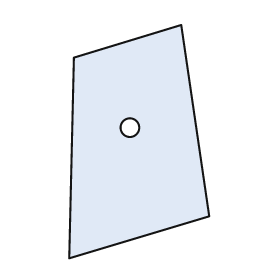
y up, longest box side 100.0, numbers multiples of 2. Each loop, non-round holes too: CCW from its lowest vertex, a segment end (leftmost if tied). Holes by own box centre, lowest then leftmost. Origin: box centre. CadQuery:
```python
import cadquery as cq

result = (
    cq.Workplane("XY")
    .moveTo(-30.0, -50.0)
    .lineTo(30.0, -32.0)
    .lineTo(18.0, 50.0)
    .lineTo(-28.0, 36.0)
    .close()
    .moveTo(-4.0, 6.0)
    .circle(4.0)
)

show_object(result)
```